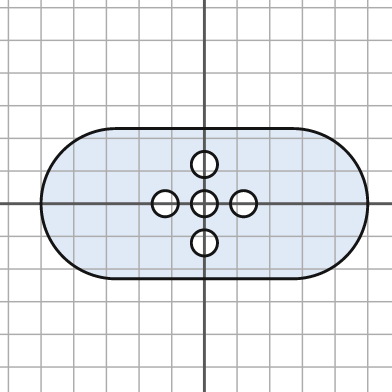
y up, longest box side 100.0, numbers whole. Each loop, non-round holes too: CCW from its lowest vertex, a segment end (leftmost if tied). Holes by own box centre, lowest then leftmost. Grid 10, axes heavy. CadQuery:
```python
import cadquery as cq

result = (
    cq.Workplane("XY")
    .moveTo(-27.0, -23.0)
    .lineTo(27.0, -23.0)
    .threePointArc((50.0, 0.0), (27.0, 23.0))
    .lineTo(-27.0, 23.0)
    .threePointArc((-50.0, 0.0), (-27.0, -23.0))
    .close()
    .moveTo(0.0, -12.0)
    .circle(4.0)
    .moveTo(-12.0, 0.0)
    .circle(4.0)
    .moveTo(0.0, 0.0)
    .circle(4.0)
    .moveTo(12.0, 0.0)
    .circle(4.0)
    .moveTo(0.0, 12.0)
    .circle(4.0)
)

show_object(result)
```